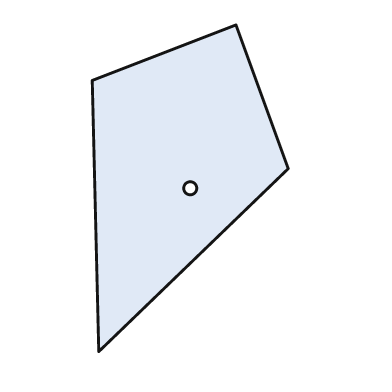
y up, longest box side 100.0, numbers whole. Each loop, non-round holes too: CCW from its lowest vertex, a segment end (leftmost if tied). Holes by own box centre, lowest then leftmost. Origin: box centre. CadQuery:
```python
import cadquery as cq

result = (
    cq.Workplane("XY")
    .moveTo(-28.0, -50.0)
    .lineTo(30.0, 6.0)
    .lineTo(14.0, 50.0)
    .lineTo(-30.0, 33.0)
    .close()
    .moveTo(0.0, 0.0)
    .circle(2.0)
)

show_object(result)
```